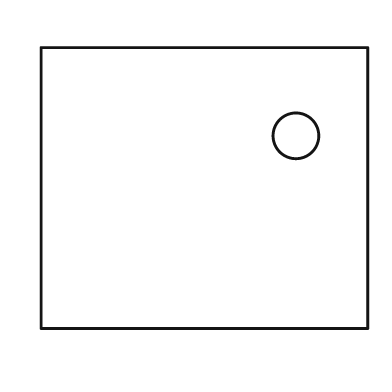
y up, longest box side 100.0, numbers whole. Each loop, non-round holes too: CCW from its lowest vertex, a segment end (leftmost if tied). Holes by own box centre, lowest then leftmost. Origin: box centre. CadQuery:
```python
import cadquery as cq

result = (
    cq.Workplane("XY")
    .moveTo(-50.0, -43.0)
    .lineTo(50.0, -43.0)
    .lineTo(50.0, 43.0)
    .lineTo(-50.0, 43.0)
    .close()
    .moveTo(28.0, 16.0)
    .circle(7.0)
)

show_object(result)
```